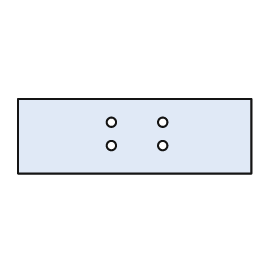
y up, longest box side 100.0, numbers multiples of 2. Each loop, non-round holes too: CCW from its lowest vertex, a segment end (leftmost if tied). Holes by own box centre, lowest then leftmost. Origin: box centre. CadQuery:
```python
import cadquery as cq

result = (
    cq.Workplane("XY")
    .moveTo(-50.0, -16.0)
    .lineTo(50.0, -16.0)
    .lineTo(50.0, 16.0)
    .lineTo(-50.0, 16.0)
    .close()
    .moveTo(-10.0, -4.0)
    .circle(2.0)
    .moveTo(12.0, -4.0)
    .circle(2.0)
    .moveTo(-10.0, 6.0)
    .circle(2.0)
    .moveTo(12.0, 6.0)
    .circle(2.0)
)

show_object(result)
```